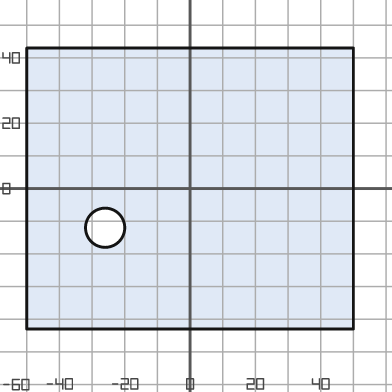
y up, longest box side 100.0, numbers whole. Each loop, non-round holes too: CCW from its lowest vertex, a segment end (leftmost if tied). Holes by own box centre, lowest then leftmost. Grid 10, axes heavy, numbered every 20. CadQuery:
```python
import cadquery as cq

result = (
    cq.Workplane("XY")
    .moveTo(-50.0, -43.0)
    .lineTo(50.0, -43.0)
    .lineTo(50.0, 43.0)
    .lineTo(-50.0, 43.0)
    .close()
    .moveTo(-26.0, -12.0)
    .circle(6.0)
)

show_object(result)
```